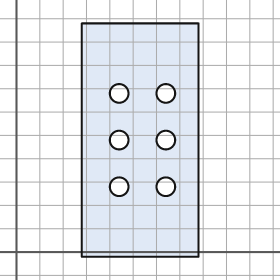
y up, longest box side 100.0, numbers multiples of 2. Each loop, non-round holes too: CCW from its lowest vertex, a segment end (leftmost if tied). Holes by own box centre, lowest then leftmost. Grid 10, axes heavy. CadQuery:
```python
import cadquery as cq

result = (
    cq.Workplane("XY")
    .moveTo(28.0, -2.0)
    .lineTo(78.0, -2.0)
    .lineTo(78.0, 98.0)
    .lineTo(28.0, 98.0)
    .close()
    .moveTo(44.0, 28.0)
    .circle(4.0)
    .moveTo(64.0, 28.0)
    .circle(4.0)
    .moveTo(44.0, 48.0)
    .circle(4.0)
    .moveTo(64.0, 48.0)
    .circle(4.0)
    .moveTo(44.0, 68.0)
    .circle(4.0)
    .moveTo(64.0, 68.0)
    .circle(4.0)
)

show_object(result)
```